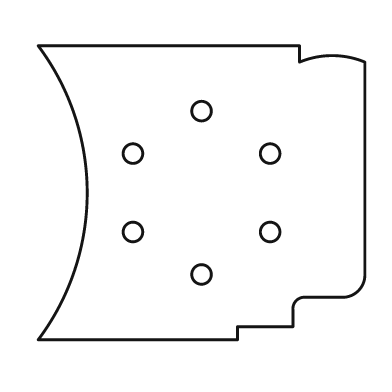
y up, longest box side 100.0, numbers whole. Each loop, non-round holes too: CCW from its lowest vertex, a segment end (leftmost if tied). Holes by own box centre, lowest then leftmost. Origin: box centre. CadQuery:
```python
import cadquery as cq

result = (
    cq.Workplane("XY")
    .moveTo(-50.0, -45.0)
    .lineTo(11.0, -45.0)
    .lineTo(11.0, -41.0)
    .lineTo(28.0, -41.0)
    .lineTo(28.0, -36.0)
    .threePointArc((29.0, -33.0), (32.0, -32.0))
    .lineTo(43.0, -32.0)
    .threePointArc((48.0, -30.0), (50.0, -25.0))
    .lineTo(50.0, 40.0)
    .threePointArc((40.0, 42.0), (30.0, 40.0))
    .lineTo(30.0, 45.0)
    .lineTo(-50.0, 45.0)
    .threePointArc((-35.0, 0.0), (-50.0, -45.0))
    .close()
    .moveTo(0.0, -25.0)
    .circle(3.0)
    .moveTo(-21.0, -12.0)
    .circle(3.0)
    .moveTo(21.0, -12.0)
    .circle(3.0)
    .moveTo(-21.0, 12.0)
    .circle(3.0)
    .moveTo(21.0, 12.0)
    .circle(3.0)
    .moveTo(0.0, 25.0)
    .circle(3.0)
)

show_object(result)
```